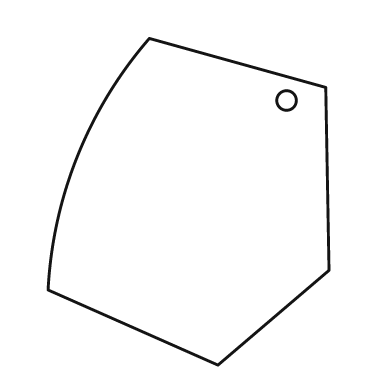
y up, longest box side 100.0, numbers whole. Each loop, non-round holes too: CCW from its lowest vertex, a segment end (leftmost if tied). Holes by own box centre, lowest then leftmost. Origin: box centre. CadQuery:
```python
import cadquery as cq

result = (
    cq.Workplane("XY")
    .moveTo(9.0, -50.0)
    .lineTo(43.0, -21.0)
    .lineTo(42.0, 35.0)
    .lineTo(-12.0, 50.0)
    .threePointArc((-34.0, 14.0), (-43.0, -27.0))
    .close()
    .moveTo(30.0, 31.0)
    .circle(3.0)
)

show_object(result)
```